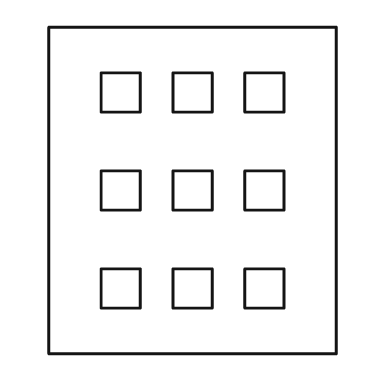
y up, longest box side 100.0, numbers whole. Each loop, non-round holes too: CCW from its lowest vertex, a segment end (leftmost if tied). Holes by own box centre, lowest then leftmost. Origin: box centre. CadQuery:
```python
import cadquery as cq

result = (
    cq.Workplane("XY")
    .moveTo(-44.0, -50.0)
    .lineTo(44.0, -50.0)
    .lineTo(44.0, 50.0)
    .lineTo(-44.0, 50.0)
    .close()
    .moveTo(-28.0, -36.0)
    .lineTo(-16.0, -36.0)
    .lineTo(-16.0, -24.0)
    .lineTo(-28.0, -24.0)
    .close()
    .moveTo(-6.0, -36.0)
    .lineTo(6.0, -36.0)
    .lineTo(6.0, -24.0)
    .lineTo(-6.0, -24.0)
    .close()
    .moveTo(16.0, -36.0)
    .lineTo(28.0, -36.0)
    .lineTo(28.0, -24.0)
    .lineTo(16.0, -24.0)
    .close()
    .moveTo(-28.0, -6.0)
    .lineTo(-16.0, -6.0)
    .lineTo(-16.0, 6.0)
    .lineTo(-28.0, 6.0)
    .close()
    .moveTo(-6.0, -6.0)
    .lineTo(6.0, -6.0)
    .lineTo(6.0, 6.0)
    .lineTo(-6.0, 6.0)
    .close()
    .moveTo(16.0, -6.0)
    .lineTo(28.0, -6.0)
    .lineTo(28.0, 6.0)
    .lineTo(16.0, 6.0)
    .close()
    .moveTo(-28.0, 24.0)
    .lineTo(-16.0, 24.0)
    .lineTo(-16.0, 36.0)
    .lineTo(-28.0, 36.0)
    .close()
    .moveTo(-6.0, 24.0)
    .lineTo(6.0, 24.0)
    .lineTo(6.0, 36.0)
    .lineTo(-6.0, 36.0)
    .close()
    .moveTo(16.0, 24.0)
    .lineTo(28.0, 24.0)
    .lineTo(28.0, 36.0)
    .lineTo(16.0, 36.0)
    .close()
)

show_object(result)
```